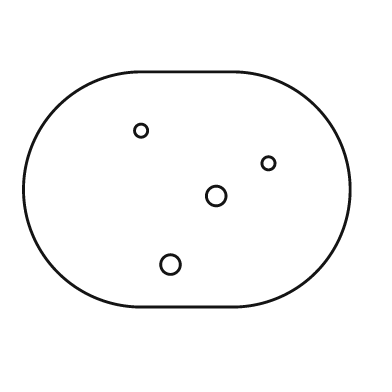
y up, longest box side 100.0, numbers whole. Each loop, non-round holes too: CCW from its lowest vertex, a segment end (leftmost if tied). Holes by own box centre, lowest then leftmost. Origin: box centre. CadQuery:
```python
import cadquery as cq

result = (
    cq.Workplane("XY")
    .moveTo(-14.0, -36.0)
    .lineTo(14.0, -36.0)
    .threePointArc((50.0, 0.0), (14.0, 36.0))
    .lineTo(-14.0, 36.0)
    .threePointArc((-50.0, 0.0), (-14.0, -36.0))
    .close()
    .moveTo(-5.0, -23.0)
    .circle(3.0)
    .moveTo(9.0, -2.0)
    .circle(3.0)
    .moveTo(25.0, 8.0)
    .circle(2.0)
    .moveTo(-14.0, 18.0)
    .circle(2.0)
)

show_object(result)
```